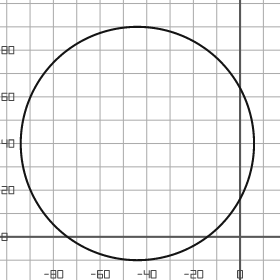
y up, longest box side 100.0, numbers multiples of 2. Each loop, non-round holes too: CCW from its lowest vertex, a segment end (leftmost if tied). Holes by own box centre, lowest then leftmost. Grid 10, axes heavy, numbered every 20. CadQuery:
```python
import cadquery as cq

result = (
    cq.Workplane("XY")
    .moveTo(-44.0, 40.0)
    .circle(50.0)
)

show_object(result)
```